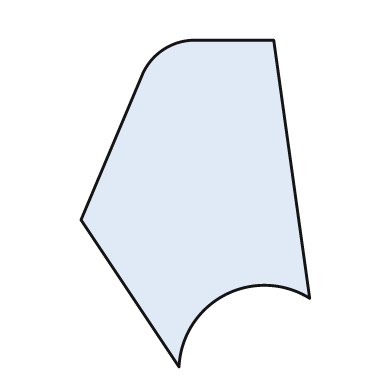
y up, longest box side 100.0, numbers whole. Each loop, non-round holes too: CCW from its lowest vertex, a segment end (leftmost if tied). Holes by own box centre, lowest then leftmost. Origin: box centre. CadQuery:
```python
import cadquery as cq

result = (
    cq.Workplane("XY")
    .moveTo(-5.0, -50.0)
    .threePointArc((9.0, -28.0), (35.0, -29.0))
    .lineTo(24.0, 50.0)
    .lineTo(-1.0, 50.0)
    .threePointArc((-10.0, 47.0), (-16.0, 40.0))
    .lineTo(-35.0, -5.0)
    .close()
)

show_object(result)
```